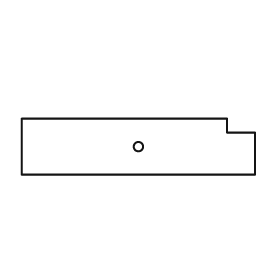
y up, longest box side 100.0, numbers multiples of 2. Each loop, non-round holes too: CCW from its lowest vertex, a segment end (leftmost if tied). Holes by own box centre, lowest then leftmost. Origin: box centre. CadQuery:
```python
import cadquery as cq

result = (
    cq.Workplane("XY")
    .moveTo(-50.0, -12.0)
    .lineTo(50.0, -12.0)
    .lineTo(50.0, 6.0)
    .lineTo(38.0, 6.0)
    .lineTo(38.0, 12.0)
    .lineTo(-50.0, 12.0)
    .close()
    .moveTo(0.0, 0.0)
    .circle(2.0)
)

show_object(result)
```